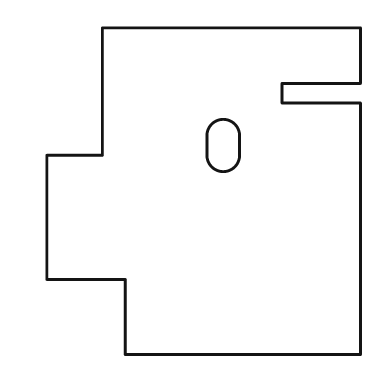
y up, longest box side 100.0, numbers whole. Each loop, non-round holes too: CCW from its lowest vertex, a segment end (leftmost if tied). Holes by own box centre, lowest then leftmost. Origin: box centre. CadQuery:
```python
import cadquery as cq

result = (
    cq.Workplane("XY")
    .moveTo(-24.0, -50.0)
    .lineTo(48.0, -50.0)
    .lineTo(48.0, 27.0)
    .lineTo(24.0, 27.0)
    .lineTo(24.0, 33.0)
    .lineTo(48.0, 33.0)
    .lineTo(48.0, 50.0)
    .lineTo(-31.0, 50.0)
    .lineTo(-31.0, 11.0)
    .lineTo(-48.0, 11.0)
    .lineTo(-48.0, -27.0)
    .lineTo(-24.0, -27.0)
    .close()
    .moveTo(1.0, 11.0)
    .threePointArc((6.0, 6.0), (11.0, 11.0))
    .lineTo(11.0, 17.0)
    .threePointArc((6.0, 22.0), (1.0, 17.0))
    .close()
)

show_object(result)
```